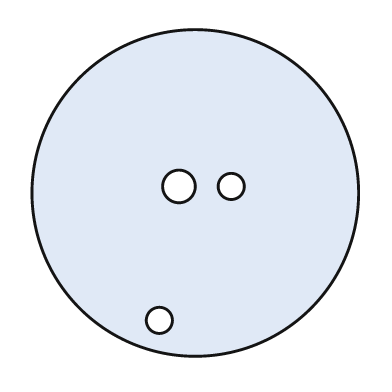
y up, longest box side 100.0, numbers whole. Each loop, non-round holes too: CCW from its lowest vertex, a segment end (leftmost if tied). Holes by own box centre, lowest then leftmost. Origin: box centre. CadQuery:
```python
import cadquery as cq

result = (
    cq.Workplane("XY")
    .moveTo(0.0, 0.0)
    .circle(50.0)
    .moveTo(-11.0, -39.0)
    .circle(4.0)
    .moveTo(-5.0, 2.0)
    .circle(5.0)
    .moveTo(11.0, 2.0)
    .circle(4.0)
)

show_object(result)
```